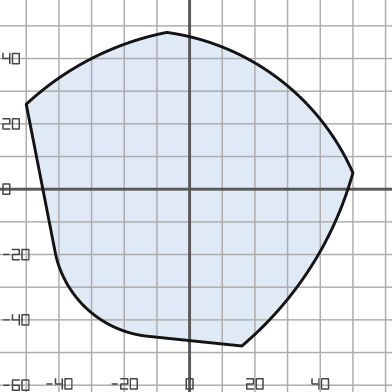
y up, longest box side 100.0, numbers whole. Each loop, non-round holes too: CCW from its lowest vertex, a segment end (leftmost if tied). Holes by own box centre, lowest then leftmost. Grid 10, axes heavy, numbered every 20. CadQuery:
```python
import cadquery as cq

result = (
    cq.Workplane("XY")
    .moveTo(16.0, -48.0)
    .threePointArc((37.0, -24.0), (50.0, 5.0))
    .threePointArc((27.0, 34.0), (-7.0, 48.0))
    .threePointArc((-30.0, 40.0), (-50.0, 26.0))
    .lineTo(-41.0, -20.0)
    .threePointArc((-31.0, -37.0), (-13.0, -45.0))
    .close()
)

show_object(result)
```